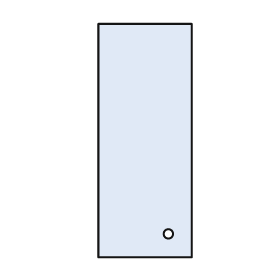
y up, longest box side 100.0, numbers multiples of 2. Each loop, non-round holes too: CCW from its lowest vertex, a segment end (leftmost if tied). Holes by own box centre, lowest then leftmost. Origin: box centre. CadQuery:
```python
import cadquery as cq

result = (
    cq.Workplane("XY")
    .moveTo(-20.0, -50.0)
    .lineTo(20.0, -50.0)
    .lineTo(20.0, 50.0)
    .lineTo(-20.0, 50.0)
    .close()
    .moveTo(10.0, -40.0)
    .circle(2.0)
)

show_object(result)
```